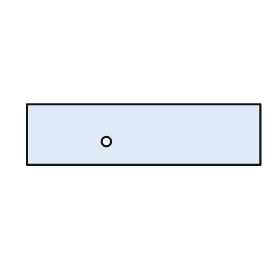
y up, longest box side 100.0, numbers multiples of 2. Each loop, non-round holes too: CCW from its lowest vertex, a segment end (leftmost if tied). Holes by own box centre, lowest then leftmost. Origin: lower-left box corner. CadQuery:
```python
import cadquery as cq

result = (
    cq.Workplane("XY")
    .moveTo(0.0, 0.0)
    .lineTo(100.0, 0.0)
    .lineTo(100.0, 26.0)
    .lineTo(0.0, 26.0)
    .close()
    .moveTo(34.0, 10.0)
    .circle(2.0)
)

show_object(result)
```